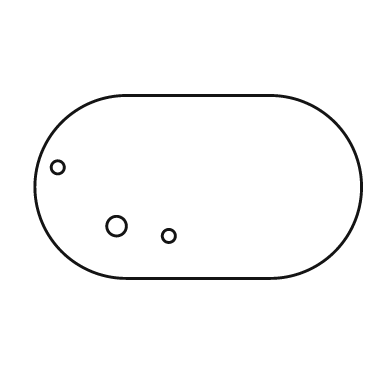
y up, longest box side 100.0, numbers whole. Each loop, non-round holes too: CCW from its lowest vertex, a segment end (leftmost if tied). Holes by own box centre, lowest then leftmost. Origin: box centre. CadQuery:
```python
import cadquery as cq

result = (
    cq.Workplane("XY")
    .moveTo(-22.0, -28.0)
    .lineTo(22.0, -28.0)
    .threePointArc((50.0, 0.0), (22.0, 28.0))
    .lineTo(-22.0, 28.0)
    .threePointArc((-50.0, 0.0), (-22.0, -28.0))
    .close()
    .moveTo(-9.0, -15.0)
    .circle(2.0)
    .moveTo(-25.0, -12.0)
    .circle(3.0)
    .moveTo(-43.0, 6.0)
    .circle(2.0)
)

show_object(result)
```